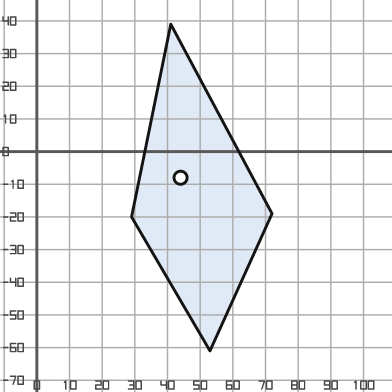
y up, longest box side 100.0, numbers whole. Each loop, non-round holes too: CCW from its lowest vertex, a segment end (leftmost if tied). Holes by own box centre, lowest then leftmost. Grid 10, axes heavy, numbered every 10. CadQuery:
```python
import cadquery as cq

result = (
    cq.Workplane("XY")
    .moveTo(53.0, -61.0)
    .lineTo(72.0, -19.0)
    .lineTo(41.0, 39.0)
    .lineTo(29.0, -20.0)
    .close()
    .moveTo(44.0, -8.0)
    .circle(2.0)
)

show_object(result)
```